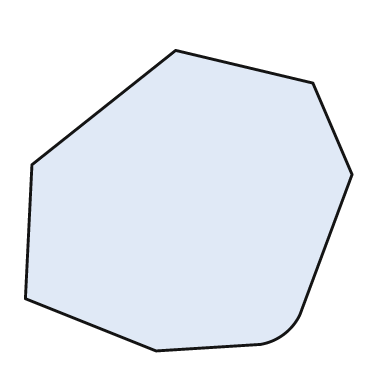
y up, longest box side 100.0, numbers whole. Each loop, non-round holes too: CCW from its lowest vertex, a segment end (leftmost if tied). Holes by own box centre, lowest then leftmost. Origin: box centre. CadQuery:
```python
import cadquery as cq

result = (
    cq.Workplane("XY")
    .moveTo(-10.0, -46.0)
    .lineTo(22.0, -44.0)
    .threePointArc((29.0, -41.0), (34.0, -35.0))
    .lineTo(50.0, 8.0)
    .lineTo(38.0, 36.0)
    .lineTo(-4.0, 46.0)
    .lineTo(-48.0, 11.0)
    .lineTo(-50.0, -30.0)
    .close()
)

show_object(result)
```